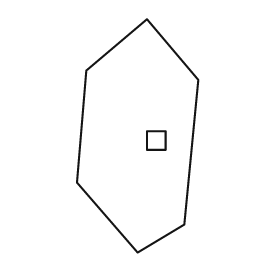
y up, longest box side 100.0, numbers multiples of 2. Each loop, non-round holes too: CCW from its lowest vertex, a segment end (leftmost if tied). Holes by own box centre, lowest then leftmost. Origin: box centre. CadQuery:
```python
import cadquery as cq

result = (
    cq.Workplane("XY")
    .moveTo(0.0, -50.0)
    .lineTo(20.0, -38.0)
    .lineTo(26.0, 24.0)
    .lineTo(4.0, 50.0)
    .lineTo(-22.0, 28.0)
    .lineTo(-26.0, -20.0)
    .close()
    .moveTo(4.0, -6.0)
    .lineTo(12.0, -6.0)
    .lineTo(12.0, 2.0)
    .lineTo(4.0, 2.0)
    .close()
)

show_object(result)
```